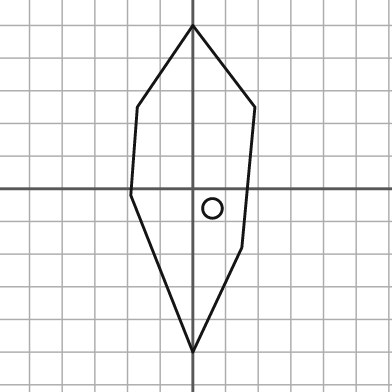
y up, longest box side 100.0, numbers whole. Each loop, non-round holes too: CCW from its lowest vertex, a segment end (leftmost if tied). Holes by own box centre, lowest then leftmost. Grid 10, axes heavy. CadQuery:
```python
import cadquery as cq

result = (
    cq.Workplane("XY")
    .moveTo(0.0, -50.0)
    .lineTo(15.0, -18.0)
    .lineTo(19.0, 25.0)
    .lineTo(0.0, 50.0)
    .lineTo(-17.0, 25.0)
    .lineTo(-19.0, -2.0)
    .close()
    .moveTo(6.0, -6.0)
    .circle(3.0)
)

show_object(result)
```